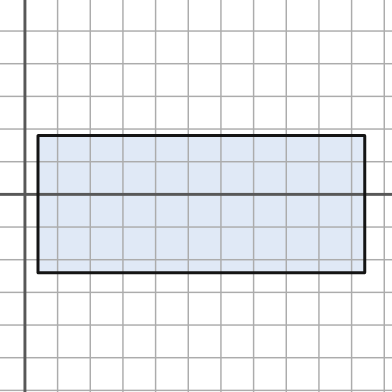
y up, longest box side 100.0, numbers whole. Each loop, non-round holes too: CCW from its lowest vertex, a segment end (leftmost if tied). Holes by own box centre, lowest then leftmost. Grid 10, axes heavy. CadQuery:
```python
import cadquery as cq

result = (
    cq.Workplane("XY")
    .moveTo(4.0, -24.0)
    .lineTo(104.0, -24.0)
    .lineTo(104.0, 18.0)
    .lineTo(4.0, 18.0)
    .close()
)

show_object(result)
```